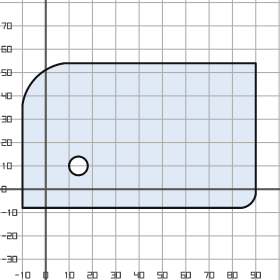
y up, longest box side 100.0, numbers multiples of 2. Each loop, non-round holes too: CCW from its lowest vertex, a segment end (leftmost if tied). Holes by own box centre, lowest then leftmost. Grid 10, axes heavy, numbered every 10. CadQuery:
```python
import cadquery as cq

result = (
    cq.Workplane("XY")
    .moveTo(-10.0, -8.0)
    .lineTo(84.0, -8.0)
    .threePointArc((88.0, -6.0), (90.0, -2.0))
    .lineTo(90.0, 54.0)
    .lineTo(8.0, 54.0)
    .threePointArc((-4.0, 48.0), (-10.0, 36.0))
    .close()
    .moveTo(14.0, 10.0)
    .circle(4.0)
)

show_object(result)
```